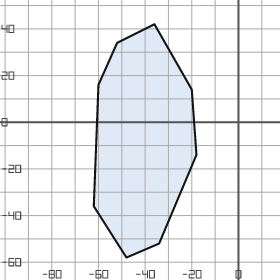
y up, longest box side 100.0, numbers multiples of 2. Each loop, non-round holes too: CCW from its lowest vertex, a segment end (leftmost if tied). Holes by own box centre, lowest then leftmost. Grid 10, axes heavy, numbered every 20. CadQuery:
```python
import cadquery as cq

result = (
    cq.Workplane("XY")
    .moveTo(-48.0, -58.0)
    .lineTo(-34.0, -52.0)
    .lineTo(-18.0, -14.0)
    .lineTo(-20.0, 14.0)
    .lineTo(-36.0, 42.0)
    .lineTo(-52.0, 34.0)
    .lineTo(-60.0, 16.0)
    .lineTo(-62.0, -36.0)
    .close()
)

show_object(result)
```